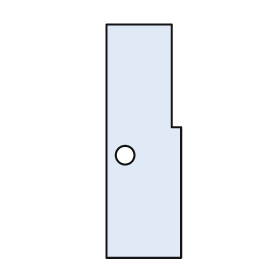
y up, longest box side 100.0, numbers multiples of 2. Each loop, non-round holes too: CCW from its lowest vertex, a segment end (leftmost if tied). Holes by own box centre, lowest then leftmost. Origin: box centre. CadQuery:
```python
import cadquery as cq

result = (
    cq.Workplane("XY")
    .moveTo(-16.0, -50.0)
    .lineTo(16.0, -50.0)
    .lineTo(16.0, 6.0)
    .lineTo(12.0, 6.0)
    .lineTo(12.0, 50.0)
    .lineTo(-16.0, 50.0)
    .close()
    .moveTo(-8.0, -6.0)
    .circle(4.0)
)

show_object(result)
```